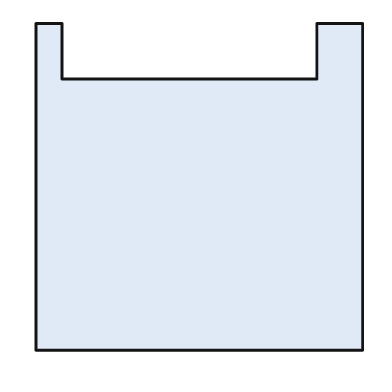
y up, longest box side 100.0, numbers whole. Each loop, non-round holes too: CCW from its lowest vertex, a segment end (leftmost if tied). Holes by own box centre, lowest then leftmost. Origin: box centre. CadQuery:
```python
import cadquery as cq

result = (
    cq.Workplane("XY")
    .moveTo(-50.0, -50.0)
    .lineTo(50.0, -50.0)
    .lineTo(50.0, 50.0)
    .lineTo(36.0, 50.0)
    .lineTo(36.0, 33.0)
    .lineTo(-42.0, 33.0)
    .lineTo(-42.0, 50.0)
    .lineTo(-50.0, 50.0)
    .close()
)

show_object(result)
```